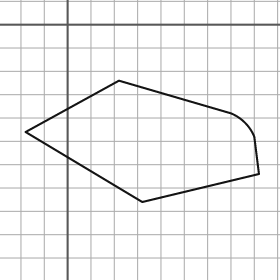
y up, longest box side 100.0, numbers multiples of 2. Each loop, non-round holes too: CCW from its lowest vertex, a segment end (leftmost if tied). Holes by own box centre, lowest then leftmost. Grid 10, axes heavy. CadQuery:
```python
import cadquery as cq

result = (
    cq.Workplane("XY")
    .moveTo(32.0, -76.0)
    .lineTo(82.0, -64.0)
    .lineTo(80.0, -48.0)
    .threePointArc((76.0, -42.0), (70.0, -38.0))
    .lineTo(22.0, -24.0)
    .lineTo(-18.0, -46.0)
    .close()
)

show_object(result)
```